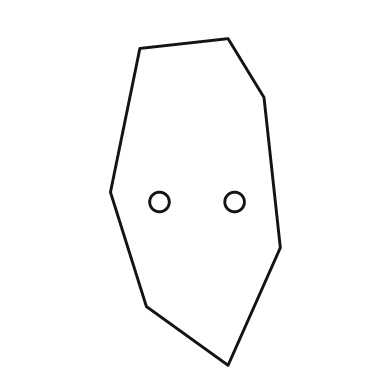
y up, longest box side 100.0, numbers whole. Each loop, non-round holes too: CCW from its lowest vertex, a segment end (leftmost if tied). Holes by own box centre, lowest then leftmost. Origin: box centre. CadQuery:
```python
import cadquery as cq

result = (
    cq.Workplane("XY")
    .moveTo(10.0, -50.0)
    .lineTo(26.0, -14.0)
    .lineTo(21.0, 32.0)
    .lineTo(10.0, 50.0)
    .lineTo(-17.0, 47.0)
    .lineTo(-26.0, 3.0)
    .lineTo(-15.0, -32.0)
    .close()
    .moveTo(-11.0, 0.0)
    .circle(3.0)
    .moveTo(12.0, 0.0)
    .circle(3.0)
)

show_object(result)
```